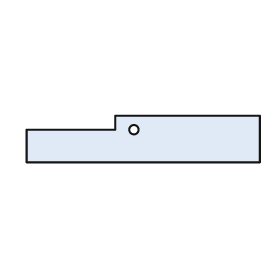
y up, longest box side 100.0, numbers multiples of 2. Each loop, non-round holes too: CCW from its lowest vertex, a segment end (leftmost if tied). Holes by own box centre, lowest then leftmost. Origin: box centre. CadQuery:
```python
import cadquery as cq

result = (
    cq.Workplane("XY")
    .moveTo(-50.0, -10.0)
    .lineTo(50.0, -10.0)
    .lineTo(50.0, 10.0)
    .lineTo(-12.0, 10.0)
    .lineTo(-12.0, 4.0)
    .lineTo(-50.0, 4.0)
    .close()
    .moveTo(-4.0, 4.0)
    .circle(2.0)
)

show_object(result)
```